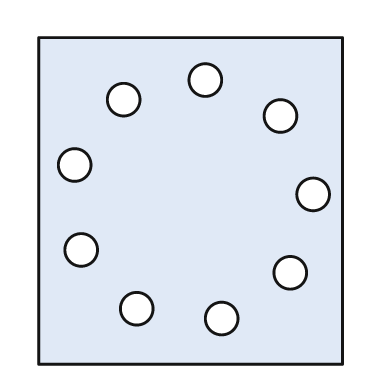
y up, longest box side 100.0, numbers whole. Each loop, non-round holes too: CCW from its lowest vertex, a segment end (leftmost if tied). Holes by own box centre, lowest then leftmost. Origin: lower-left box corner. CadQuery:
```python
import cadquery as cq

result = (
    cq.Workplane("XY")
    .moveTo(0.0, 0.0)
    .lineTo(93.0, 0.0)
    .lineTo(93.0, 100.0)
    .lineTo(0.0, 100.0)
    .close()
    .moveTo(56.0, 14.0)
    .circle(5.0)
    .moveTo(30.0, 17.0)
    .circle(5.0)
    .moveTo(77.0, 28.0)
    .circle(5.0)
    .moveTo(13.0, 35.0)
    .circle(5.0)
    .moveTo(84.0, 52.0)
    .circle(5.0)
    .moveTo(11.0, 61.0)
    .circle(5.0)
    .moveTo(74.0, 76.0)
    .circle(5.0)
    .moveTo(26.0, 81.0)
    .circle(5.0)
    .moveTo(51.0, 87.0)
    .circle(5.0)
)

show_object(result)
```